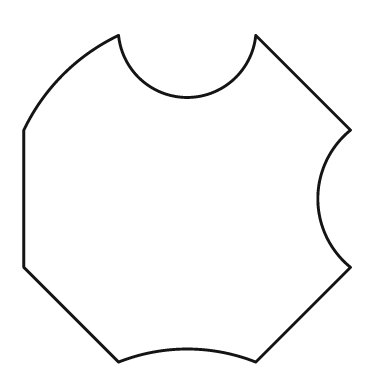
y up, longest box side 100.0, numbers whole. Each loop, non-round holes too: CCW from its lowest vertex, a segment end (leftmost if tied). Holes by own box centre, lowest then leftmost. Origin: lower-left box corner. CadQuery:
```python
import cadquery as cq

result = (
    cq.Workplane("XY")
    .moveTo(29.0, 0.0)
    .threePointArc((50.0, 4.0), (71.0, 0.0))
    .lineTo(100.0, 29.0)
    .threePointArc((90.0, 50.0), (100.0, 71.0))
    .lineTo(71.0, 100.0)
    .threePointArc((50.0, 81.0), (29.0, 100.0))
    .threePointArc((12.0, 88.0), (0.0, 71.0))
    .lineTo(0.0, 29.0)
    .close()
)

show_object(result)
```